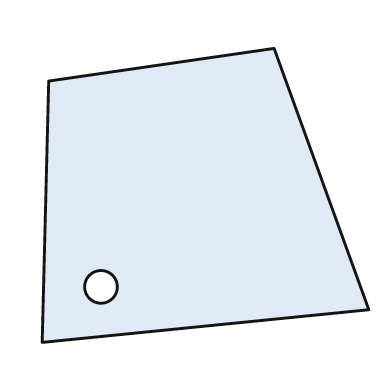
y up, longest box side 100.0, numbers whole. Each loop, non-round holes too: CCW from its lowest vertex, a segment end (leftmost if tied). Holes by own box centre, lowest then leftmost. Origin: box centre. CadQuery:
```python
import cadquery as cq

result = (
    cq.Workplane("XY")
    .moveTo(-50.0, -45.0)
    .lineTo(50.0, -35.0)
    .lineTo(21.0, 45.0)
    .lineTo(-48.0, 35.0)
    .close()
    .moveTo(-32.0, -28.0)
    .circle(5.0)
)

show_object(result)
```